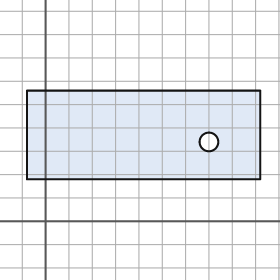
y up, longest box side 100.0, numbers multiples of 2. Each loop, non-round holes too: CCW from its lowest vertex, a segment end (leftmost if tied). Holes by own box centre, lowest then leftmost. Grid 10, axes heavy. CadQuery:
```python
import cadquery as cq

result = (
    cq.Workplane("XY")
    .moveTo(-8.0, 18.0)
    .lineTo(92.0, 18.0)
    .lineTo(92.0, 56.0)
    .lineTo(-8.0, 56.0)
    .close()
    .moveTo(70.0, 34.0)
    .circle(4.0)
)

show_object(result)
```